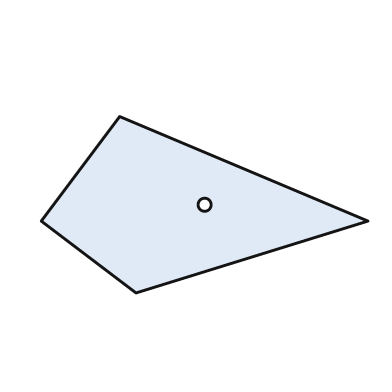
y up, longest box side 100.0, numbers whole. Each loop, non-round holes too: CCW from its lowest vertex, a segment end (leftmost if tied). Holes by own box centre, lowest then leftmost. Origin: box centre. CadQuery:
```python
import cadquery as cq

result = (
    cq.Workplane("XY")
    .moveTo(-21.0, -27.0)
    .lineTo(50.0, -5.0)
    .lineTo(-26.0, 27.0)
    .lineTo(-50.0, -5.0)
    .close()
    .moveTo(0.0, 0.0)
    .circle(2.0)
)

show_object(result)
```